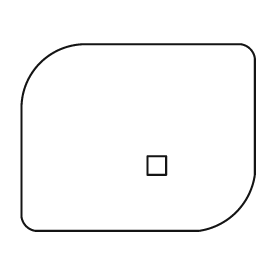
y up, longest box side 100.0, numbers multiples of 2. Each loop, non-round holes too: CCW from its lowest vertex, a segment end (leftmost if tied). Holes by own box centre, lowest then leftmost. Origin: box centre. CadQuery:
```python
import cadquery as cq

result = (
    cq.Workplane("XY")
    .moveTo(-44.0, -40.0)
    .lineTo(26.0, -40.0)
    .threePointArc((42.0, -32.0), (50.0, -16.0))
    .lineTo(50.0, 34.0)
    .threePointArc((48.0, 38.0), (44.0, 40.0))
    .lineTo(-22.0, 40.0)
    .threePointArc((-42.0, 32.0), (-50.0, 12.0))
    .lineTo(-50.0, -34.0)
    .threePointArc((-48.0, -38.0), (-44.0, -40.0))
    .close()
    .moveTo(4.0, -16.0)
    .lineTo(12.0, -16.0)
    .lineTo(12.0, -8.0)
    .lineTo(4.0, -8.0)
    .close()
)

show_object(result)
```